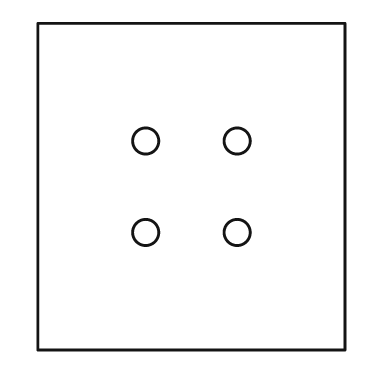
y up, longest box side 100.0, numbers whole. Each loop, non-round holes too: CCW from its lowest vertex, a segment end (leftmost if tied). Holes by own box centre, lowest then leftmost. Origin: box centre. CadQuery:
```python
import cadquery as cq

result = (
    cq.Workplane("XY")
    .moveTo(-47.0, -50.0)
    .lineTo(47.0, -50.0)
    .lineTo(47.0, 50.0)
    .lineTo(-47.0, 50.0)
    .close()
    .moveTo(-14.0, -14.0)
    .circle(4.0)
    .moveTo(14.0, -14.0)
    .circle(4.0)
    .moveTo(-14.0, 14.0)
    .circle(4.0)
    .moveTo(14.0, 14.0)
    .circle(4.0)
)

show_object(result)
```